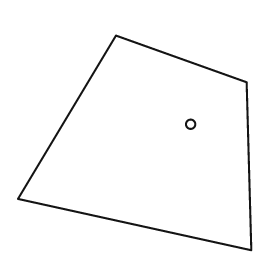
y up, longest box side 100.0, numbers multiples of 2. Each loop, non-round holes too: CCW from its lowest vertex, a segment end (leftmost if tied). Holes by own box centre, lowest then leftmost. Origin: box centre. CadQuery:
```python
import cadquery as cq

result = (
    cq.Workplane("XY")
    .moveTo(50.0, -46.0)
    .lineTo(48.0, 26.0)
    .lineTo(-8.0, 46.0)
    .lineTo(-50.0, -24.0)
    .close()
    .moveTo(24.0, 8.0)
    .circle(2.0)
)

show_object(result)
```